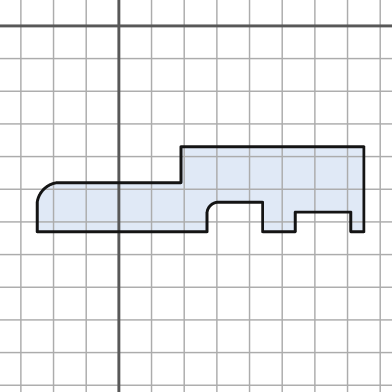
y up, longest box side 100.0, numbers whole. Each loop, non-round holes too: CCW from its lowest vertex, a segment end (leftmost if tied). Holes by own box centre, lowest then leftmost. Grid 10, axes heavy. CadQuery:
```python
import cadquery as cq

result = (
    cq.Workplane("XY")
    .moveTo(-25.0, -63.0)
    .lineTo(27.0, -63.0)
    .lineTo(27.0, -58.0)
    .threePointArc((28.0, -55.0), (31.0, -54.0))
    .lineTo(44.0, -54.0)
    .lineTo(44.0, -63.0)
    .lineTo(54.0, -63.0)
    .lineTo(54.0, -57.0)
    .lineTo(71.0, -57.0)
    .lineTo(71.0, -63.0)
    .lineTo(75.0, -63.0)
    .lineTo(75.0, -37.0)
    .lineTo(19.0, -37.0)
    .lineTo(19.0, -48.0)
    .lineTo(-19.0, -48.0)
    .threePointArc((-23.0, -50.0), (-25.0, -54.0))
    .close()
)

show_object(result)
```